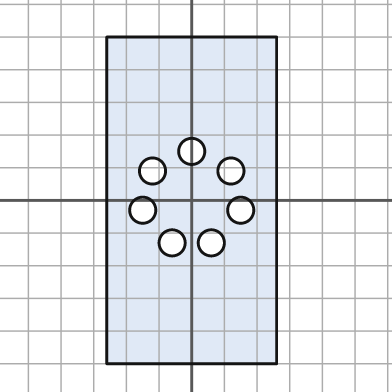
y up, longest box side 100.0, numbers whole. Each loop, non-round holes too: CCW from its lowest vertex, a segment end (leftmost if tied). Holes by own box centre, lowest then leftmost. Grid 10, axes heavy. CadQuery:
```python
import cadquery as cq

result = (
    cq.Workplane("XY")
    .moveTo(-26.0, -50.0)
    .lineTo(26.0, -50.0)
    .lineTo(26.0, 50.0)
    .lineTo(-26.0, 50.0)
    .close()
    .moveTo(-6.0, -13.0)
    .circle(4.0)
    .moveTo(6.0, -13.0)
    .circle(4.0)
    .moveTo(-15.0, -3.0)
    .circle(4.0)
    .moveTo(15.0, -3.0)
    .circle(4.0)
    .moveTo(-12.0, 9.0)
    .circle(4.0)
    .moveTo(12.0, 9.0)
    .circle(4.0)
    .moveTo(0.0, 15.0)
    .circle(4.0)
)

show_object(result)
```